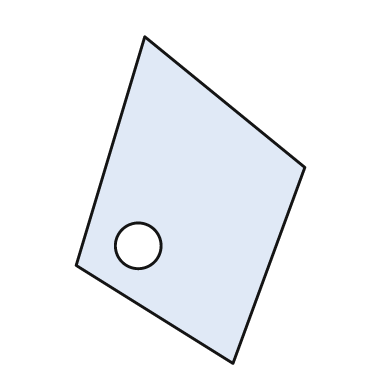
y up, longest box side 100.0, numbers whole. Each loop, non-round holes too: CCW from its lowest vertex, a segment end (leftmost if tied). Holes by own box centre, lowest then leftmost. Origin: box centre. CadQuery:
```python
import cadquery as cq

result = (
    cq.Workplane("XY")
    .moveTo(13.0, -50.0)
    .lineTo(35.0, 10.0)
    .lineTo(-14.0, 50.0)
    .lineTo(-35.0, -20.0)
    .close()
    .moveTo(-16.0, -14.0)
    .circle(7.0)
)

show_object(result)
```